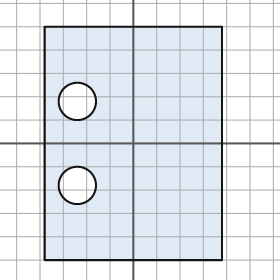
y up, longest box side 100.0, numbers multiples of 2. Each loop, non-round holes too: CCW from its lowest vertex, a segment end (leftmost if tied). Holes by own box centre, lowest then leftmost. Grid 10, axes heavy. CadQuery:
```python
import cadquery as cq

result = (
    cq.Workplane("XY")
    .moveTo(-38.0, -50.0)
    .lineTo(38.0, -50.0)
    .lineTo(38.0, 50.0)
    .lineTo(-38.0, 50.0)
    .close()
    .moveTo(-24.0, -18.0)
    .circle(8.0)
    .moveTo(-24.0, 18.0)
    .circle(8.0)
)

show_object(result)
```